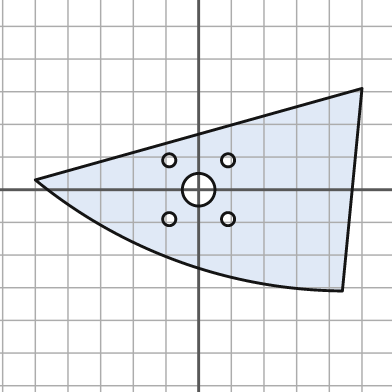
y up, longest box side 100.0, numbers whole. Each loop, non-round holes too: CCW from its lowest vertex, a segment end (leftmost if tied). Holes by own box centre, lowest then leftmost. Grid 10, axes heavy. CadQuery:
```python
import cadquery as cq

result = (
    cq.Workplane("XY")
    .moveTo(44.0, -31.0)
    .lineTo(50.0, 31.0)
    .lineTo(-50.0, 3.0)
    .threePointArc((-6.0, -22.0), (44.0, -31.0))
    .close()
    .moveTo(-9.0, -9.0)
    .circle(2.0)
    .moveTo(9.0, -9.0)
    .circle(2.0)
    .moveTo(0.0, 0.0)
    .circle(5.0)
    .moveTo(-9.0, 9.0)
    .circle(2.0)
    .moveTo(9.0, 9.0)
    .circle(2.0)
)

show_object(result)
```